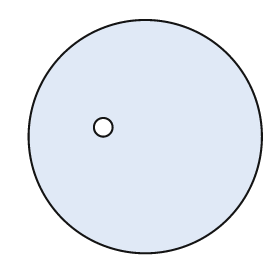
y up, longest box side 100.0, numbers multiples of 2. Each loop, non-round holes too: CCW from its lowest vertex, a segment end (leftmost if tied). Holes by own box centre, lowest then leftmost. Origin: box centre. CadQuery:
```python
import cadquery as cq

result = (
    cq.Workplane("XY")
    .moveTo(0.0, 0.0)
    .circle(50.0)
    .moveTo(-18.0, 4.0)
    .circle(4.0)
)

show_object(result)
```